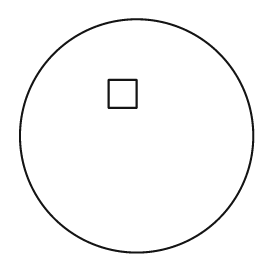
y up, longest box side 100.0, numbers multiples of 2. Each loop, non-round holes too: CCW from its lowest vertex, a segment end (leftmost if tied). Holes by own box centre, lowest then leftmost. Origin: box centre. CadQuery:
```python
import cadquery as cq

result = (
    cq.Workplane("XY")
    .moveTo(0.0, 0.0)
    .circle(50.0)
    .moveTo(-12.0, 12.0)
    .lineTo(0.0, 12.0)
    .lineTo(0.0, 24.0)
    .lineTo(-12.0, 24.0)
    .close()
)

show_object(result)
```